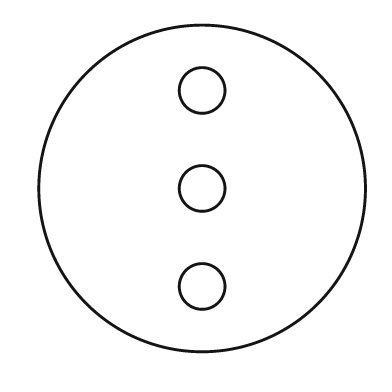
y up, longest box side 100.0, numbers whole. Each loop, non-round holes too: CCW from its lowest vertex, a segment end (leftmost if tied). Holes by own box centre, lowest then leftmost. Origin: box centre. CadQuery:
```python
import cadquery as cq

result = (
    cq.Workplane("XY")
    .moveTo(0.0, 0.0)
    .circle(50.0)
    .moveTo(0.0, -30.0)
    .circle(7.0)
    .moveTo(0.0, 0.0)
    .circle(7.0)
    .moveTo(0.0, 30.0)
    .circle(7.0)
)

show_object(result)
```